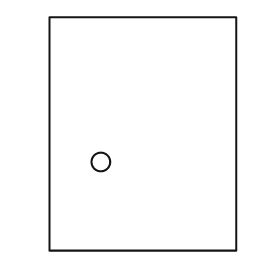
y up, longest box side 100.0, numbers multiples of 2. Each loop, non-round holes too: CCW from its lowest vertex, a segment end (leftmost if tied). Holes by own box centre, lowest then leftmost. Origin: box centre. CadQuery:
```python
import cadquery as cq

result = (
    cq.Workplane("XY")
    .moveTo(-40.0, -50.0)
    .lineTo(40.0, -50.0)
    .lineTo(40.0, 50.0)
    .lineTo(-40.0, 50.0)
    .close()
    .moveTo(-18.0, -12.0)
    .circle(4.0)
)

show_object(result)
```